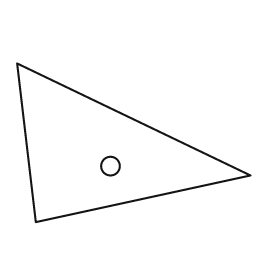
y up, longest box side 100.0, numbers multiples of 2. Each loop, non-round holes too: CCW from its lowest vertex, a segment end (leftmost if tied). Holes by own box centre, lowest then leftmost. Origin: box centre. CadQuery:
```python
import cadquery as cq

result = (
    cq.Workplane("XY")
    .moveTo(-42.0, -34.0)
    .lineTo(50.0, -14.0)
    .lineTo(-50.0, 34.0)
    .close()
    .moveTo(-10.0, -10.0)
    .circle(4.0)
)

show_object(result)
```